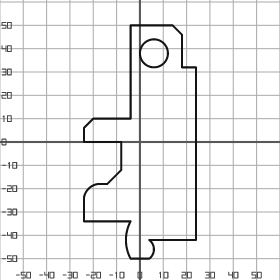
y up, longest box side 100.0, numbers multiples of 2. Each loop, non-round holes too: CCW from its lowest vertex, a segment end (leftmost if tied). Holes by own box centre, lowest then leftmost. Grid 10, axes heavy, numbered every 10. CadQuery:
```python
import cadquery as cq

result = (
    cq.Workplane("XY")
    .moveTo(-4.0, -50.0)
    .lineTo(4.0, -50.0)
    .threePointArc((6.0, -46.0), (4.0, -42.0))
    .lineTo(24.0, -42.0)
    .lineTo(24.0, 32.0)
    .lineTo(18.0, 32.0)
    .lineTo(18.0, 46.0)
    .lineTo(14.0, 50.0)
    .lineTo(-4.0, 50.0)
    .lineTo(-4.0, 10.0)
    .lineTo(-20.0, 10.0)
    .lineTo(-24.0, 6.0)
    .lineTo(-24.0, 0.0)
    .lineTo(-8.0, 0.0)
    .lineTo(-8.0, -12.0)
    .lineTo(-14.0, -18.0)
    .lineTo(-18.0, -18.0)
    .threePointArc((-22.0, -20.0), (-24.0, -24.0))
    .lineTo(-24.0, -34.0)
    .lineTo(-4.0, -34.0)
    .threePointArc((-6.0, -42.0), (-4.0, -50.0))
    .close()
    .moveTo(6.0, 38.0)
    .circle(6.0)
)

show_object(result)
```